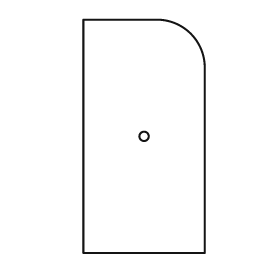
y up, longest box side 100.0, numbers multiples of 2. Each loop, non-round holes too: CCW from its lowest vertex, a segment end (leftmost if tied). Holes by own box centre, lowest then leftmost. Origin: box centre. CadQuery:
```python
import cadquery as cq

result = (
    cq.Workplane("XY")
    .moveTo(-26.0, -50.0)
    .lineTo(26.0, -50.0)
    .lineTo(26.0, 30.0)
    .threePointArc((20.0, 44.0), (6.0, 50.0))
    .lineTo(-26.0, 50.0)
    .close()
    .moveTo(0.0, 0.0)
    .circle(2.0)
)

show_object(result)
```